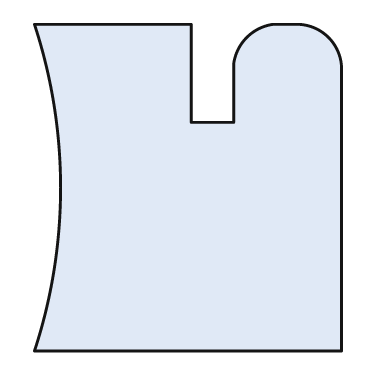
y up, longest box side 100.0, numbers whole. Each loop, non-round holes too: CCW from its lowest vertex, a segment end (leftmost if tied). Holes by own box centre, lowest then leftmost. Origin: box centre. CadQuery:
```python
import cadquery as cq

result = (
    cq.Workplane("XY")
    .moveTo(-47.0, -50.0)
    .lineTo(47.0, -50.0)
    .lineTo(47.0, 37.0)
    .threePointArc((43.0, 46.0), (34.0, 50.0))
    .lineTo(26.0, 50.0)
    .threePointArc((18.0, 46.0), (14.0, 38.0))
    .lineTo(14.0, 20.0)
    .lineTo(1.0, 20.0)
    .lineTo(1.0, 50.0)
    .lineTo(-47.0, 50.0)
    .threePointArc((-39.0, 0.0), (-47.0, -50.0))
    .close()
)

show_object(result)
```